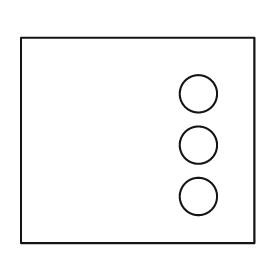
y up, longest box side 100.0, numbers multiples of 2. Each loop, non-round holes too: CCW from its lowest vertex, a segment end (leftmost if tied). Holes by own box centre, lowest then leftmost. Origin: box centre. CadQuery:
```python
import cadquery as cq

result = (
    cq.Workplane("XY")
    .moveTo(-50.0, -44.0)
    .lineTo(50.0, -44.0)
    .lineTo(50.0, 44.0)
    .lineTo(-50.0, 44.0)
    .close()
    .moveTo(26.0, -24.0)
    .circle(8.0)
    .moveTo(26.0, -2.0)
    .circle(8.0)
    .moveTo(26.0, 20.0)
    .circle(8.0)
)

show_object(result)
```